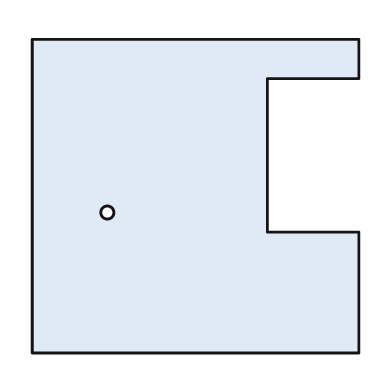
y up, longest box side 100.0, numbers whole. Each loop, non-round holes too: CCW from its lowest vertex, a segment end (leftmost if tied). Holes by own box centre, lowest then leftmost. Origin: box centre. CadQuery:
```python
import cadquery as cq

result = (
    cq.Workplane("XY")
    .moveTo(-50.0, -48.0)
    .lineTo(50.0, -48.0)
    .lineTo(50.0, -11.0)
    .lineTo(22.0, -11.0)
    .lineTo(22.0, 36.0)
    .lineTo(50.0, 36.0)
    .lineTo(50.0, 48.0)
    .lineTo(-50.0, 48.0)
    .close()
    .moveTo(-27.0, -5.0)
    .circle(2.0)
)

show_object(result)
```